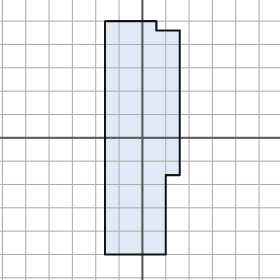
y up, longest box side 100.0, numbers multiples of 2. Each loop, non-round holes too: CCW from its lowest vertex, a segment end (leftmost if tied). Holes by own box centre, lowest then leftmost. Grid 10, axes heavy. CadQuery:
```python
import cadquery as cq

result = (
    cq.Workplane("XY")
    .moveTo(-16.0, -50.0)
    .lineTo(10.0, -50.0)
    .lineTo(10.0, -16.0)
    .lineTo(16.0, -16.0)
    .lineTo(16.0, 46.0)
    .lineTo(6.0, 46.0)
    .lineTo(6.0, 50.0)
    .lineTo(-16.0, 50.0)
    .close()
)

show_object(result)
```